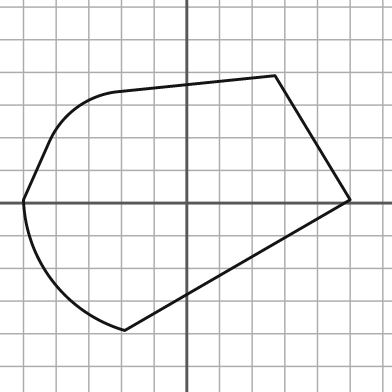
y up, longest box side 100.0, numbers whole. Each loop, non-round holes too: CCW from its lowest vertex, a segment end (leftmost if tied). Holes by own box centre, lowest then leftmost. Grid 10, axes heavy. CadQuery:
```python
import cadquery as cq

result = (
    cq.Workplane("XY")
    .moveTo(-19.0, -39.0)
    .lineTo(50.0, 1.0)
    .lineTo(27.0, 39.0)
    .lineTo(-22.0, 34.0)
    .threePointArc((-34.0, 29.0), (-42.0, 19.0))
    .lineTo(-50.0, 1.0)
    .threePointArc((-41.0, -24.0), (-19.0, -39.0))
    .close()
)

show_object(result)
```